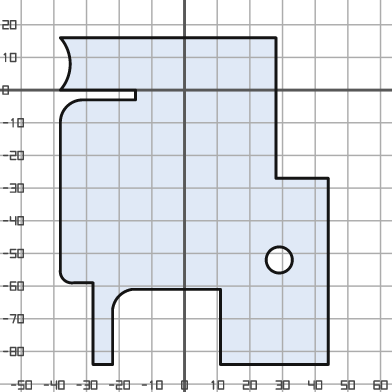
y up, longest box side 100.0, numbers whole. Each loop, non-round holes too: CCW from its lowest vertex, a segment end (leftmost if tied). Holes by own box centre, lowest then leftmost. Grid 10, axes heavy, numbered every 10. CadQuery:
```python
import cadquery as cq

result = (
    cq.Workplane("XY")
    .moveTo(-28.0, -84.0)
    .lineTo(-22.0, -84.0)
    .lineTo(-22.0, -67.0)
    .threePointArc((-20.0, -63.0), (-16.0, -61.0))
    .lineTo(11.0, -61.0)
    .lineTo(11.0, -84.0)
    .lineTo(44.0, -84.0)
    .lineTo(44.0, -27.0)
    .lineTo(28.0, -27.0)
    .lineTo(28.0, 16.0)
    .lineTo(-38.0, 16.0)
    .threePointArc((-35.0, 8.0), (-38.0, 0.0))
    .lineTo(-15.0, 0.0)
    .lineTo(-15.0, -3.0)
    .lineTo(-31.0, -3.0)
    .threePointArc((-36.0, -5.0), (-38.0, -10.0))
    .lineTo(-38.0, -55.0)
    .threePointArc((-37.0, -58.0), (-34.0, -59.0))
    .lineTo(-28.0, -59.0)
    .close()
    .moveTo(29.0, -52.0)
    .circle(4.0)
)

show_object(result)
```